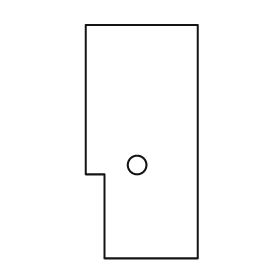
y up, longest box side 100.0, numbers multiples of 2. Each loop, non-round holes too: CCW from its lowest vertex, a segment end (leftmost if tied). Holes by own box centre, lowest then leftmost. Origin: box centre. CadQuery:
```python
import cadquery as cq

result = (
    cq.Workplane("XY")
    .moveTo(-16.0, -50.0)
    .lineTo(24.0, -50.0)
    .lineTo(24.0, 50.0)
    .lineTo(-24.0, 50.0)
    .lineTo(-24.0, -14.0)
    .lineTo(-16.0, -14.0)
    .close()
    .moveTo(-2.0, -10.0)
    .circle(4.0)
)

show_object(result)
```